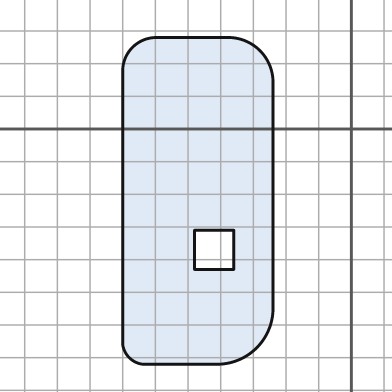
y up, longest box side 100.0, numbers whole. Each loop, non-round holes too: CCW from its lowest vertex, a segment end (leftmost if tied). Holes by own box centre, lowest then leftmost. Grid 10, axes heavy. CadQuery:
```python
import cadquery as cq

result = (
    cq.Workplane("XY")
    .moveTo(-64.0, -72.0)
    .lineTo(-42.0, -72.0)
    .threePointArc((-29.0, -67.0), (-24.0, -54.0))
    .lineTo(-24.0, 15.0)
    .threePointArc((-28.0, 24.0), (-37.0, 28.0))
    .lineTo(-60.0, 28.0)
    .threePointArc((-67.0, 25.0), (-70.0, 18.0))
    .lineTo(-70.0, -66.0)
    .threePointArc((-68.0, -70.0), (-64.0, -72.0))
    .close()
    .moveTo(-48.0, -43.0)
    .lineTo(-36.0, -43.0)
    .lineTo(-36.0, -31.0)
    .lineTo(-48.0, -31.0)
    .close()
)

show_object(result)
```